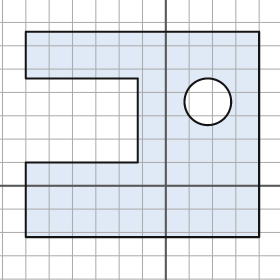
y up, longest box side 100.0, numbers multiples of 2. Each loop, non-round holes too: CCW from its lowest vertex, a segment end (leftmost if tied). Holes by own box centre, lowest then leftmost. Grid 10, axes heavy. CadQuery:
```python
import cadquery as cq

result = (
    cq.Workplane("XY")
    .moveTo(-60.0, -22.0)
    .lineTo(40.0, -22.0)
    .lineTo(40.0, 66.0)
    .lineTo(-60.0, 66.0)
    .lineTo(-60.0, 46.0)
    .lineTo(-12.0, 46.0)
    .lineTo(-12.0, 10.0)
    .lineTo(-60.0, 10.0)
    .close()
    .moveTo(18.0, 36.0)
    .circle(10.0)
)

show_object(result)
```